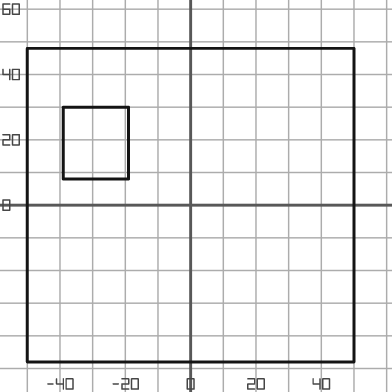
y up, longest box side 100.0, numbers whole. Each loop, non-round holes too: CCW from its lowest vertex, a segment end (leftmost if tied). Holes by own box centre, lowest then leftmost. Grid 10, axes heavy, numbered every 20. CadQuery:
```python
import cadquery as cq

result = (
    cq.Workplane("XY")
    .moveTo(-50.0, -48.0)
    .lineTo(50.0, -48.0)
    .lineTo(50.0, 48.0)
    .lineTo(-50.0, 48.0)
    .close()
    .moveTo(-39.0, 8.0)
    .lineTo(-19.0, 8.0)
    .lineTo(-19.0, 30.0)
    .lineTo(-39.0, 30.0)
    .close()
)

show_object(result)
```